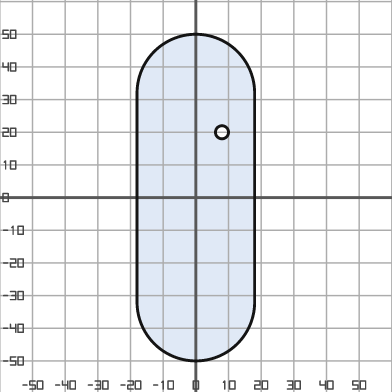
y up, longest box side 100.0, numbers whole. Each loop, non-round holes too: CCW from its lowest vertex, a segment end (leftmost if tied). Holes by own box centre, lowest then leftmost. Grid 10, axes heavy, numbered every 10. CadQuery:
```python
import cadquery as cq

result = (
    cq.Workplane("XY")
    .moveTo(-18.0, -32.0)
    .threePointArc((0.0, -50.0), (18.0, -32.0))
    .lineTo(18.0, 32.0)
    .threePointArc((0.0, 50.0), (-18.0, 32.0))
    .close()
    .moveTo(8.0, 20.0)
    .circle(2.0)
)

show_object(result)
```